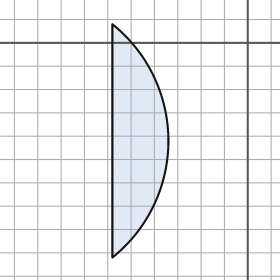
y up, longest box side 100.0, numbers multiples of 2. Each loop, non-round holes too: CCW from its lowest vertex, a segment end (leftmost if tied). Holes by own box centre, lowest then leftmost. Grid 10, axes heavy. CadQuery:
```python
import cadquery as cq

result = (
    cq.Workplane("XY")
    .moveTo(-58.0, -92.0)
    .threePointArc((-34.0, -42.0), (-58.0, 8.0))
    .close()
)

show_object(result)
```